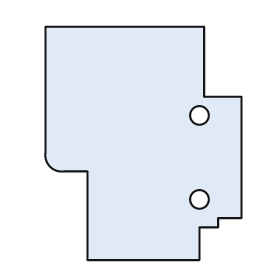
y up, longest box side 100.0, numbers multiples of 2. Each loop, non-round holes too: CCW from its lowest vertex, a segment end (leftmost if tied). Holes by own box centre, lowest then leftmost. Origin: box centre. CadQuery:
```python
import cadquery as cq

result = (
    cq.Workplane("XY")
    .moveTo(-24.0, -50.0)
    .lineTo(24.0, -50.0)
    .lineTo(24.0, -36.0)
    .lineTo(32.0, -36.0)
    .lineTo(32.0, -32.0)
    .lineTo(42.0, -32.0)
    .lineTo(42.0, 20.0)
    .lineTo(26.0, 20.0)
    .lineTo(26.0, 50.0)
    .lineTo(-42.0, 50.0)
    .lineTo(-42.0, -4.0)
    .threePointArc((-40.0, -10.0), (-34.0, -12.0))
    .lineTo(-24.0, -12.0)
    .close()
    .moveTo(24.0, -24.0)
    .circle(4.0)
    .moveTo(24.0, 12.0)
    .circle(4.0)
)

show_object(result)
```